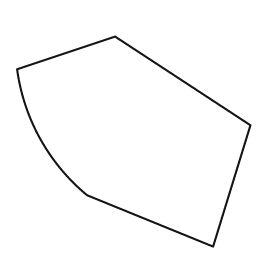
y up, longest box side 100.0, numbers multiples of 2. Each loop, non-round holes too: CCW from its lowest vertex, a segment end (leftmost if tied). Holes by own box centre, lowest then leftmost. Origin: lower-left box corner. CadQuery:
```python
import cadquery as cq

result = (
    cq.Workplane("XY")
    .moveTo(84.0, 0.0)
    .lineTo(100.0, 52.0)
    .lineTo(42.0, 90.0)
    .lineTo(0.0, 76.0)
    .threePointArc((10.0, 46.0), (30.0, 22.0))
    .close()
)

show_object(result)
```